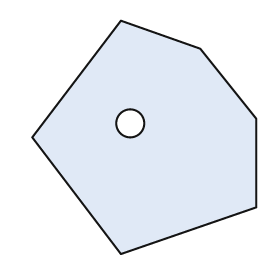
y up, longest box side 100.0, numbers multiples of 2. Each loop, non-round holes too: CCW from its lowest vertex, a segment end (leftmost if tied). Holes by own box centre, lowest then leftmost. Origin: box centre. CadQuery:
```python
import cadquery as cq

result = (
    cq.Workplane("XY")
    .moveTo(-10.0, -50.0)
    .lineTo(48.0, -30.0)
    .lineTo(48.0, 8.0)
    .lineTo(24.0, 38.0)
    .lineTo(-10.0, 50.0)
    .lineTo(-48.0, 0.0)
    .close()
    .moveTo(-6.0, 6.0)
    .circle(6.0)
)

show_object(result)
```